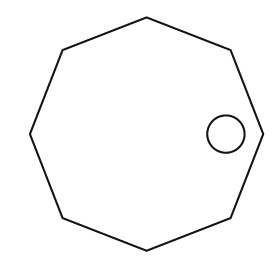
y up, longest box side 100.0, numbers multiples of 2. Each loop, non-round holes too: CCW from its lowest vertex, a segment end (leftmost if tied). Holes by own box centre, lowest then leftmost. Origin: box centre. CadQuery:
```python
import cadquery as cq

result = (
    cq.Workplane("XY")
    .moveTo(0.0, -50.0)
    .lineTo(36.0, -36.0)
    .lineTo(50.0, 0.0)
    .lineTo(36.0, 36.0)
    .lineTo(0.0, 50.0)
    .lineTo(-36.0, 36.0)
    .lineTo(-50.0, 0.0)
    .lineTo(-36.0, -36.0)
    .close()
    .moveTo(34.0, 0.0)
    .circle(8.0)
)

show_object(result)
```